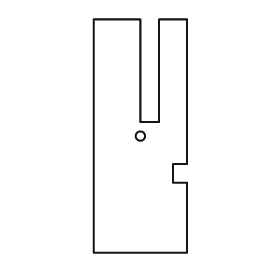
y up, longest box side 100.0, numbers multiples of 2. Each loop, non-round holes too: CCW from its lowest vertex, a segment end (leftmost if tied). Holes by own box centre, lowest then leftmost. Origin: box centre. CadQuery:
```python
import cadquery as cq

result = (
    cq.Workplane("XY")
    .moveTo(-20.0, -50.0)
    .lineTo(20.0, -50.0)
    .lineTo(20.0, -20.0)
    .lineTo(14.0, -20.0)
    .lineTo(14.0, -12.0)
    .lineTo(20.0, -12.0)
    .lineTo(20.0, 50.0)
    .lineTo(8.0, 50.0)
    .lineTo(8.0, 6.0)
    .lineTo(0.0, 6.0)
    .lineTo(0.0, 50.0)
    .lineTo(-20.0, 50.0)
    .close()
    .moveTo(0.0, 0.0)
    .circle(2.0)
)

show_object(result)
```